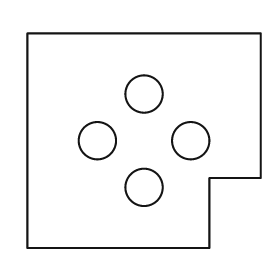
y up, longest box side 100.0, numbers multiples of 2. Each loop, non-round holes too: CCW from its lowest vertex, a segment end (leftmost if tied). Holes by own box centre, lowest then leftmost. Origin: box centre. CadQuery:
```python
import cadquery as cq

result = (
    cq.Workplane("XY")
    .moveTo(-50.0, -46.0)
    .lineTo(28.0, -46.0)
    .lineTo(28.0, -16.0)
    .lineTo(50.0, -16.0)
    .lineTo(50.0, 46.0)
    .lineTo(-50.0, 46.0)
    .close()
    .moveTo(0.0, -20.0)
    .circle(8.0)
    .moveTo(-20.0, 0.0)
    .circle(8.0)
    .moveTo(20.0, 0.0)
    .circle(8.0)
    .moveTo(0.0, 20.0)
    .circle(8.0)
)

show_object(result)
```